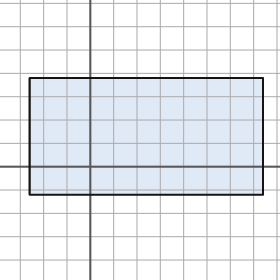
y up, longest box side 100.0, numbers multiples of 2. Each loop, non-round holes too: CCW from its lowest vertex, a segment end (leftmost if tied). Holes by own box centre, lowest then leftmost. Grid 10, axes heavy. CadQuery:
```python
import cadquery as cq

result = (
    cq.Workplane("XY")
    .moveTo(-26.0, -12.0)
    .lineTo(74.0, -12.0)
    .lineTo(74.0, 38.0)
    .lineTo(-26.0, 38.0)
    .close()
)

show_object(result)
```